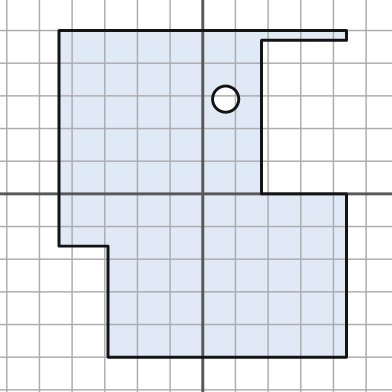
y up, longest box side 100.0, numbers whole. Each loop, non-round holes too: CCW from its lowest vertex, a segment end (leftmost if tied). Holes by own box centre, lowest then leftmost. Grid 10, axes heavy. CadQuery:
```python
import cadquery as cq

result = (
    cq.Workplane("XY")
    .moveTo(-29.0, -50.0)
    .lineTo(44.0, -50.0)
    .lineTo(44.0, 0.0)
    .lineTo(18.0, 0.0)
    .lineTo(18.0, 47.0)
    .lineTo(44.0, 47.0)
    .lineTo(44.0, 50.0)
    .lineTo(-44.0, 50.0)
    .lineTo(-44.0, -16.0)
    .lineTo(-29.0, -16.0)
    .close()
    .moveTo(7.0, 29.0)
    .circle(4.0)
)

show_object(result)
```